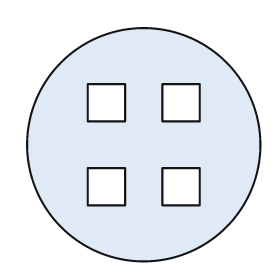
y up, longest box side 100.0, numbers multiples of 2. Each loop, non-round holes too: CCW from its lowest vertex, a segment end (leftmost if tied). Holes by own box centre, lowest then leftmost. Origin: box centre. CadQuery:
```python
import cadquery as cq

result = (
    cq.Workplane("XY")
    .moveTo(0.0, 0.0)
    .circle(50.0)
    .moveTo(-24.0, -26.0)
    .lineTo(-8.0, -26.0)
    .lineTo(-8.0, -10.0)
    .lineTo(-24.0, -10.0)
    .close()
    .moveTo(8.0, -26.0)
    .lineTo(24.0, -26.0)
    .lineTo(24.0, -10.0)
    .lineTo(8.0, -10.0)
    .close()
    .moveTo(-24.0, 10.0)
    .lineTo(-8.0, 10.0)
    .lineTo(-8.0, 26.0)
    .lineTo(-24.0, 26.0)
    .close()
    .moveTo(8.0, 10.0)
    .lineTo(24.0, 10.0)
    .lineTo(24.0, 26.0)
    .lineTo(8.0, 26.0)
    .close()
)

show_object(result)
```